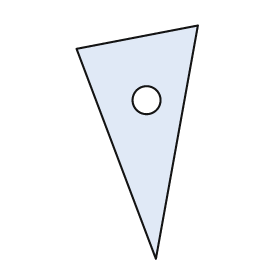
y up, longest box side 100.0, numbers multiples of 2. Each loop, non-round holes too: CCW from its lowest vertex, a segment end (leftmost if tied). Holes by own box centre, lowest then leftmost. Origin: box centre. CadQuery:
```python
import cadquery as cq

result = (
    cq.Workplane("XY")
    .moveTo(8.0, -50.0)
    .lineTo(26.0, 50.0)
    .lineTo(-26.0, 40.0)
    .close()
    .moveTo(4.0, 18.0)
    .circle(6.0)
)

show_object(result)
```